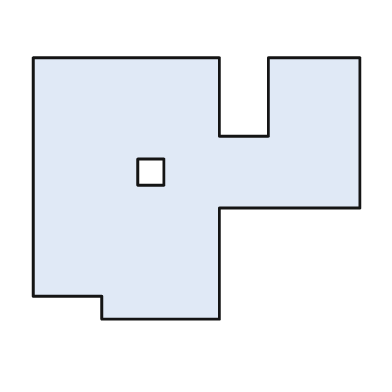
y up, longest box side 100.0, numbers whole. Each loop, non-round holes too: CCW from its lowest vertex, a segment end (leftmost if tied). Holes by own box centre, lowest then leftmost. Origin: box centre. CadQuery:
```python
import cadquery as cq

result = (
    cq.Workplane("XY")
    .moveTo(-29.0, -40.0)
    .lineTo(7.0, -40.0)
    .lineTo(7.0, -6.0)
    .lineTo(50.0, -6.0)
    .lineTo(50.0, 40.0)
    .lineTo(22.0, 40.0)
    .lineTo(22.0, 16.0)
    .lineTo(7.0, 16.0)
    .lineTo(7.0, 40.0)
    .lineTo(-50.0, 40.0)
    .lineTo(-50.0, -33.0)
    .lineTo(-29.0, -33.0)
    .close()
    .moveTo(-18.0, 1.0)
    .lineTo(-10.0, 1.0)
    .lineTo(-10.0, 9.0)
    .lineTo(-18.0, 9.0)
    .close()
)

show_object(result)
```